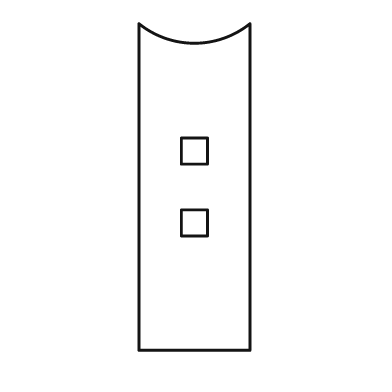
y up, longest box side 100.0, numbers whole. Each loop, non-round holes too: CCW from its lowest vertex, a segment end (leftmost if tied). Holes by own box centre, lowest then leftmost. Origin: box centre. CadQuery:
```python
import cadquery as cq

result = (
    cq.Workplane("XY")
    .moveTo(-17.0, -50.0)
    .lineTo(17.0, -50.0)
    .lineTo(17.0, 50.0)
    .threePointArc((0.0, 44.0), (-17.0, 50.0))
    .close()
    .moveTo(-4.0, -15.0)
    .lineTo(4.0, -15.0)
    .lineTo(4.0, -7.0)
    .lineTo(-4.0, -7.0)
    .close()
    .moveTo(-4.0, 7.0)
    .lineTo(4.0, 7.0)
    .lineTo(4.0, 15.0)
    .lineTo(-4.0, 15.0)
    .close()
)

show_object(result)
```